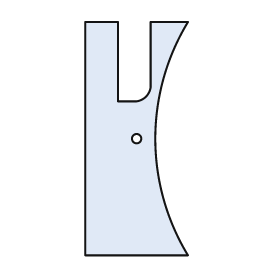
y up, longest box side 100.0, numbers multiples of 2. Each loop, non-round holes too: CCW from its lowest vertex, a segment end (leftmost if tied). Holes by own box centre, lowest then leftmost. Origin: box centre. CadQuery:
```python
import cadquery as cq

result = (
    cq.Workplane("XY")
    .moveTo(-22.0, -50.0)
    .lineTo(22.0, -50.0)
    .threePointArc((8.0, 0.0), (22.0, 50.0))
    .lineTo(6.0, 50.0)
    .lineTo(6.0, 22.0)
    .threePointArc((4.0, 18.0), (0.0, 16.0))
    .lineTo(-8.0, 16.0)
    .lineTo(-8.0, 50.0)
    .lineTo(-22.0, 50.0)
    .close()
    .moveTo(0.0, 0.0)
    .circle(2.0)
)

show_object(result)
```